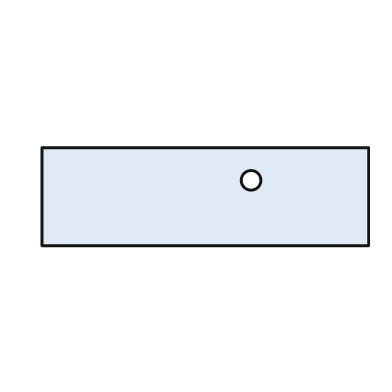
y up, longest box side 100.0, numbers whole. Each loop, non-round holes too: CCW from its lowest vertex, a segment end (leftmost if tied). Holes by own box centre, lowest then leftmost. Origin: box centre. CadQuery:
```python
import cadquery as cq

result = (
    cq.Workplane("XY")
    .moveTo(-50.0, -15.0)
    .lineTo(50.0, -15.0)
    .lineTo(50.0, 15.0)
    .lineTo(-50.0, 15.0)
    .close()
    .moveTo(14.0, 5.0)
    .circle(3.0)
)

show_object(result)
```